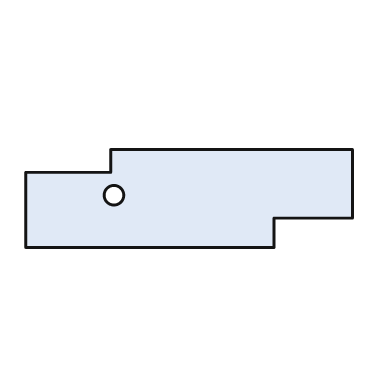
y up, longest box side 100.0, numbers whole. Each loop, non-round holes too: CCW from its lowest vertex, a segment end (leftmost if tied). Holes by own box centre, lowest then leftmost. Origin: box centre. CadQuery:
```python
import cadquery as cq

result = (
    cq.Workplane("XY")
    .moveTo(-50.0, -15.0)
    .lineTo(26.0, -15.0)
    .lineTo(26.0, -6.0)
    .lineTo(50.0, -6.0)
    .lineTo(50.0, 15.0)
    .lineTo(-24.0, 15.0)
    .lineTo(-24.0, 8.0)
    .lineTo(-50.0, 8.0)
    .close()
    .moveTo(-23.0, 1.0)
    .circle(3.0)
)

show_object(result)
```